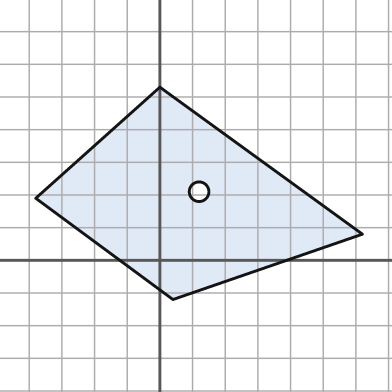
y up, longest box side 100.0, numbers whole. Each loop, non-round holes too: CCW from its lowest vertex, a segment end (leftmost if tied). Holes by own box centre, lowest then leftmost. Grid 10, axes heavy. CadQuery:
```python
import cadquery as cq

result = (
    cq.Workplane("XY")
    .moveTo(4.0, -12.0)
    .lineTo(62.0, 8.0)
    .lineTo(0.0, 53.0)
    .lineTo(-38.0, 19.0)
    .close()
    .moveTo(12.0, 21.0)
    .circle(3.0)
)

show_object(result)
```